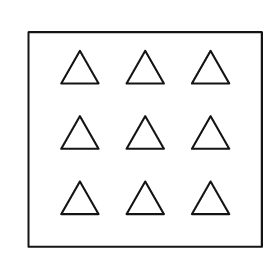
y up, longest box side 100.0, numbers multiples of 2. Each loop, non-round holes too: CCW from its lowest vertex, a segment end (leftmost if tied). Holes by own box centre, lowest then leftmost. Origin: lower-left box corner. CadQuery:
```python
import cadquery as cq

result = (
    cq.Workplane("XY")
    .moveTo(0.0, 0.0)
    .lineTo(100.0, 0.0)
    .lineTo(100.0, 92.0)
    .lineTo(0.0, 92.0)
    .close()
    .moveTo(14.0, 14.0)
    .lineTo(30.0, 14.0)
    .lineTo(22.0, 28.0)
    .close()
    .moveTo(42.0, 14.0)
    .lineTo(58.0, 14.0)
    .lineTo(50.0, 28.0)
    .close()
    .moveTo(70.0, 14.0)
    .lineTo(86.0, 14.0)
    .lineTo(78.0, 28.0)
    .close()
    .moveTo(14.0, 42.0)
    .lineTo(30.0, 42.0)
    .lineTo(22.0, 56.0)
    .close()
    .moveTo(42.0, 42.0)
    .lineTo(58.0, 42.0)
    .lineTo(50.0, 56.0)
    .close()
    .moveTo(70.0, 42.0)
    .lineTo(86.0, 42.0)
    .lineTo(78.0, 56.0)
    .close()
    .moveTo(14.0, 70.0)
    .lineTo(30.0, 70.0)
    .lineTo(22.0, 84.0)
    .close()
    .moveTo(42.0, 70.0)
    .lineTo(58.0, 70.0)
    .lineTo(50.0, 84.0)
    .close()
    .moveTo(70.0, 70.0)
    .lineTo(86.0, 70.0)
    .lineTo(78.0, 84.0)
    .close()
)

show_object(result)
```